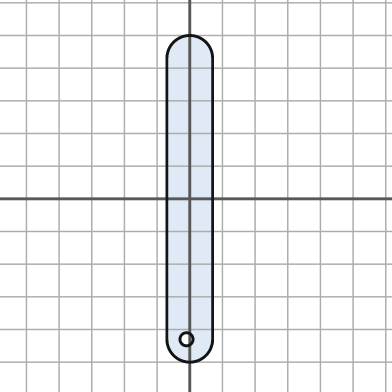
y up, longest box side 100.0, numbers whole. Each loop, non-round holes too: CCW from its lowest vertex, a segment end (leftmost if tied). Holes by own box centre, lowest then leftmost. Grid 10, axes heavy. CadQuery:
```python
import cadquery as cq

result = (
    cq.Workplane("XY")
    .moveTo(-7.0, -43.0)
    .threePointArc((0.0, -50.0), (7.0, -43.0))
    .lineTo(7.0, 43.0)
    .threePointArc((0.0, 50.0), (-7.0, 43.0))
    .close()
    .moveTo(-1.0, -43.0)
    .circle(2.0)
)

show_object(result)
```